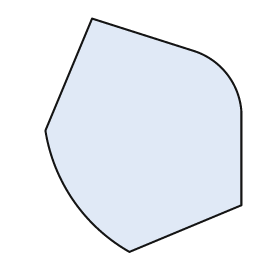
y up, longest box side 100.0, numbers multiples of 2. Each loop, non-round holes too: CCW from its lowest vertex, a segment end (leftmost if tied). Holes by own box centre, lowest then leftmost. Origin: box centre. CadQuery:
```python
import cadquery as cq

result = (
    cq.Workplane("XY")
    .moveTo(-6.0, -50.0)
    .lineTo(42.0, -30.0)
    .lineTo(42.0, 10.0)
    .threePointArc((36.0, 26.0), (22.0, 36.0))
    .lineTo(-22.0, 50.0)
    .lineTo(-42.0, 2.0)
    .threePointArc((-30.0, -28.0), (-6.0, -50.0))
    .close()
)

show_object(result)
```